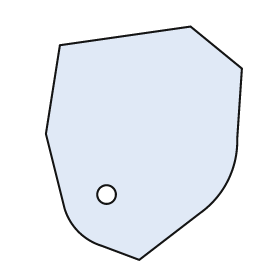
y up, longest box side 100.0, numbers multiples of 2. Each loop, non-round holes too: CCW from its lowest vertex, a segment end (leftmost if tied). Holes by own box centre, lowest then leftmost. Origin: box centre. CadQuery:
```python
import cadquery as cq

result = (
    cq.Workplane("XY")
    .moveTo(-2.0, -50.0)
    .lineTo(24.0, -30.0)
    .threePointArc((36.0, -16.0), (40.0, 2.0))
    .lineTo(42.0, 32.0)
    .lineTo(20.0, 50.0)
    .lineTo(-36.0, 42.0)
    .lineTo(-42.0, 4.0)
    .lineTo(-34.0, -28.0)
    .threePointArc((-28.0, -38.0), (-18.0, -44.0))
    .close()
    .moveTo(-16.0, -22.0)
    .circle(4.0)
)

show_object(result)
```